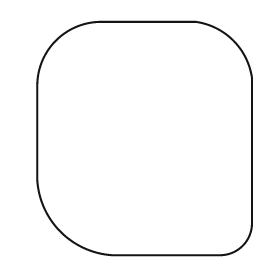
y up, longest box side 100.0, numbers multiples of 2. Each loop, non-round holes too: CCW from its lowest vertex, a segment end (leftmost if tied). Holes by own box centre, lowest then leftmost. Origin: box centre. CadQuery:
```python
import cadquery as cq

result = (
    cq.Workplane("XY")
    .moveTo(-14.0, -50.0)
    .lineTo(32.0, -50.0)
    .threePointArc((42.0, -46.0), (46.0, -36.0))
    .lineTo(46.0, 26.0)
    .threePointArc((38.0, 42.0), (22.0, 50.0))
    .lineTo(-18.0, 50.0)
    .threePointArc((-38.0, 42.0), (-46.0, 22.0))
    .lineTo(-46.0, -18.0)
    .threePointArc((-36.0, -40.0), (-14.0, -50.0))
    .close()
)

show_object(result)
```